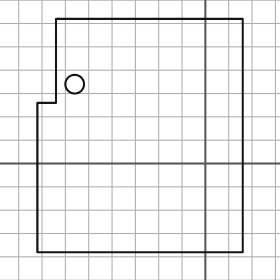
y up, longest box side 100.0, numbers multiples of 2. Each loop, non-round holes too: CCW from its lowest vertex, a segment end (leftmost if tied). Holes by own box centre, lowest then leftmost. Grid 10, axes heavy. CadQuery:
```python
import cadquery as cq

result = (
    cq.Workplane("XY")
    .moveTo(-72.0, -38.0)
    .lineTo(16.0, -38.0)
    .lineTo(16.0, 62.0)
    .lineTo(-64.0, 62.0)
    .lineTo(-64.0, 26.0)
    .lineTo(-72.0, 26.0)
    .close()
    .moveTo(-56.0, 34.0)
    .circle(4.0)
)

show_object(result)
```